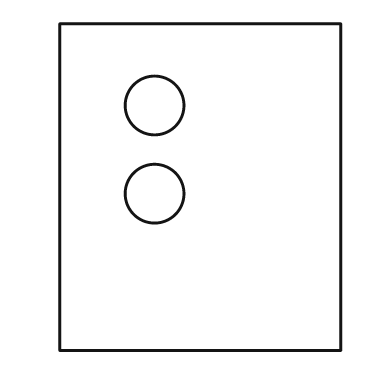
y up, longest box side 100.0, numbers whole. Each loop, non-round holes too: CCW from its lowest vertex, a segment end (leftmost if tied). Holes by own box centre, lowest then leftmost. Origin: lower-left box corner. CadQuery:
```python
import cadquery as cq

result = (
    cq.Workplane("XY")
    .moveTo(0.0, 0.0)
    .lineTo(86.0, 0.0)
    .lineTo(86.0, 100.0)
    .lineTo(0.0, 100.0)
    .close()
    .moveTo(29.0, 48.0)
    .circle(9.0)
    .moveTo(29.0, 75.0)
    .circle(9.0)
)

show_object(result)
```